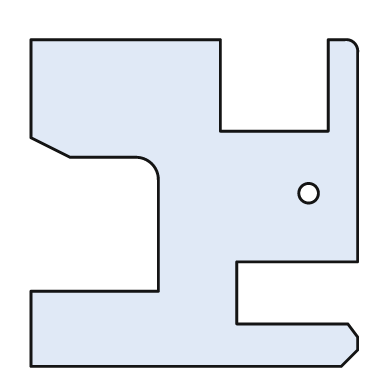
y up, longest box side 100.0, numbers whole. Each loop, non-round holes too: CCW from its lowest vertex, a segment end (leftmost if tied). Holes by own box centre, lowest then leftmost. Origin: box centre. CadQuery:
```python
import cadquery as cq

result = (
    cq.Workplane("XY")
    .moveTo(-50.0, -50.0)
    .lineTo(45.0, -50.0)
    .lineTo(50.0, -45.0)
    .lineTo(50.0, -41.0)
    .lineTo(47.0, -37.0)
    .lineTo(13.0, -37.0)
    .lineTo(13.0, -18.0)
    .lineTo(50.0, -18.0)
    .lineTo(50.0, 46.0)
    .threePointArc((49.0, 49.0), (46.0, 50.0))
    .lineTo(41.0, 50.0)
    .lineTo(41.0, 22.0)
    .lineTo(8.0, 22.0)
    .lineTo(8.0, 50.0)
    .lineTo(-50.0, 50.0)
    .lineTo(-50.0, 20.0)
    .lineTo(-38.0, 14.0)
    .lineTo(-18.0, 14.0)
    .threePointArc((-13.0, 12.0), (-11.0, 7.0))
    .lineTo(-11.0, -27.0)
    .lineTo(-50.0, -27.0)
    .close()
    .moveTo(35.0, 3.0)
    .circle(3.0)
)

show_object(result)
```